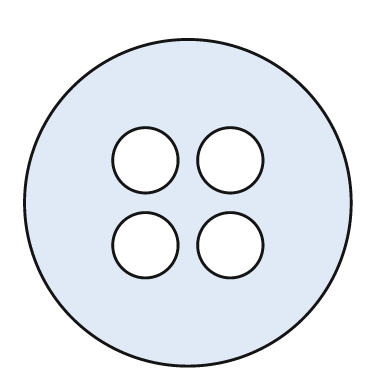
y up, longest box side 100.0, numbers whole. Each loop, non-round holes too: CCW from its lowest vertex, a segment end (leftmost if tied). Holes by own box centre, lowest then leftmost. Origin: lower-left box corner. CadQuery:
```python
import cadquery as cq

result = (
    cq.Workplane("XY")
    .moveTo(50.0, 50.0)
    .circle(50.0)
    .moveTo(37.0, 37.0)
    .circle(10.0)
    .moveTo(63.0, 37.0)
    .circle(10.0)
    .moveTo(37.0, 63.0)
    .circle(10.0)
    .moveTo(63.0, 63.0)
    .circle(10.0)
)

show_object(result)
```